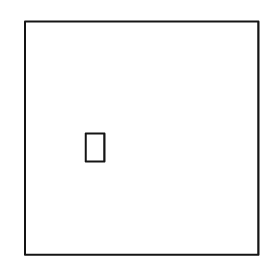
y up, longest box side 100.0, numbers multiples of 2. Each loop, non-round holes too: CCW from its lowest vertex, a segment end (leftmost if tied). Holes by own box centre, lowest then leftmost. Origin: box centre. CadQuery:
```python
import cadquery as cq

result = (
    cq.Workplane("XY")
    .moveTo(-50.0, -50.0)
    .lineTo(50.0, -50.0)
    .lineTo(50.0, 50.0)
    .lineTo(-50.0, 50.0)
    .close()
    .moveTo(-24.0, -10.0)
    .lineTo(-16.0, -10.0)
    .lineTo(-16.0, 2.0)
    .lineTo(-24.0, 2.0)
    .close()
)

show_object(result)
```